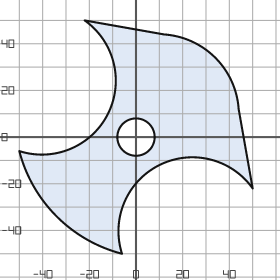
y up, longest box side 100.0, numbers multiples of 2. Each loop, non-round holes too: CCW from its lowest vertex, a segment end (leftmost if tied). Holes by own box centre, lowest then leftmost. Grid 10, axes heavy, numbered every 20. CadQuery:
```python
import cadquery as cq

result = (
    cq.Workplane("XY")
    .moveTo(-6.0, -50.0)
    .threePointArc((10.0, -12.0), (50.0, -22.0))
    .lineTo(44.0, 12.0)
    .threePointArc((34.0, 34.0), (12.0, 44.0))
    .lineTo(-22.0, 50.0)
    .threePointArc((-12.0, 10.0), (-50.0, -6.0))
    .threePointArc((-34.0, -34.0), (-6.0, -50.0))
    .close()
    .moveTo(0.0, 0.0)
    .circle(8.0)
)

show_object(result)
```